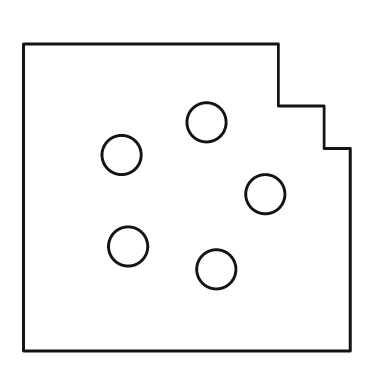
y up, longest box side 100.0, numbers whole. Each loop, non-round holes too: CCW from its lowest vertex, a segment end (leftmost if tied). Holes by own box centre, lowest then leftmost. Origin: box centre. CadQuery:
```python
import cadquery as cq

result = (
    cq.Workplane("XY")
    .moveTo(-50.0, -47.0)
    .lineTo(50.0, -47.0)
    .lineTo(50.0, 15.0)
    .lineTo(42.0, 15.0)
    .lineTo(42.0, 28.0)
    .lineTo(28.0, 28.0)
    .lineTo(28.0, 47.0)
    .lineTo(-50.0, 47.0)
    .close()
    .moveTo(9.0, -22.0)
    .circle(6.0)
    .moveTo(-18.0, -15.0)
    .circle(6.0)
    .moveTo(24.0, 1.0)
    .circle(6.0)
    .moveTo(-20.0, 13.0)
    .circle(6.0)
    .moveTo(6.0, 23.0)
    .circle(6.0)
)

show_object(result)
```